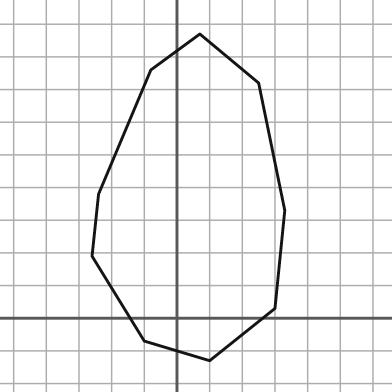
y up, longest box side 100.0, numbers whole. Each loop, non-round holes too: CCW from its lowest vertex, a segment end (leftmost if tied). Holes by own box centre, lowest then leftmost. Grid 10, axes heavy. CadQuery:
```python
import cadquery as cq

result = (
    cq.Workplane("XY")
    .moveTo(10.0, -13.0)
    .lineTo(30.0, 3.0)
    .lineTo(33.0, 33.0)
    .lineTo(25.0, 72.0)
    .lineTo(7.0, 87.0)
    .lineTo(-8.0, 76.0)
    .lineTo(-24.0, 38.0)
    .lineTo(-26.0, 19.0)
    .lineTo(-10.0, -7.0)
    .close()
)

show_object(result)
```